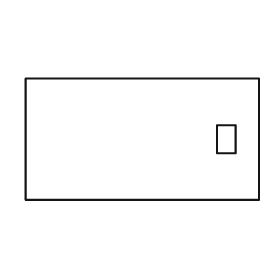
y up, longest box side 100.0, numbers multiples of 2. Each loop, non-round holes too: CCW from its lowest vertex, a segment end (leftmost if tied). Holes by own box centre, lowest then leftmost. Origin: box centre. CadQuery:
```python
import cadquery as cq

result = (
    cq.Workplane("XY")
    .moveTo(-50.0, -26.0)
    .lineTo(50.0, -26.0)
    .lineTo(50.0, 26.0)
    .lineTo(-50.0, 26.0)
    .close()
    .moveTo(32.0, -6.0)
    .lineTo(40.0, -6.0)
    .lineTo(40.0, 6.0)
    .lineTo(32.0, 6.0)
    .close()
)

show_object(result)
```